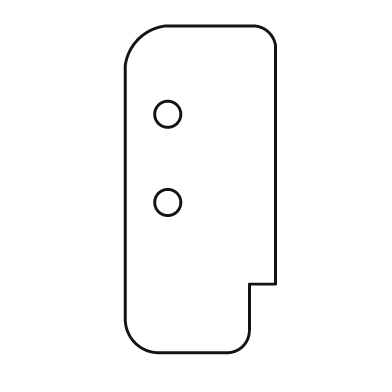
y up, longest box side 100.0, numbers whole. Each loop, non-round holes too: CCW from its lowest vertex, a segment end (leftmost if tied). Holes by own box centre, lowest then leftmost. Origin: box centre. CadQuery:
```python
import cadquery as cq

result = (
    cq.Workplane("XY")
    .moveTo(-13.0, -50.0)
    .lineTo(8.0, -50.0)
    .threePointArc((13.0, -48.0), (15.0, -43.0))
    .lineTo(15.0, -29.0)
    .lineTo(23.0, -29.0)
    .lineTo(23.0, 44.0)
    .threePointArc((21.0, 48.0), (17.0, 50.0))
    .lineTo(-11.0, 50.0)
    .threePointArc((-19.0, 46.0), (-23.0, 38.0))
    .lineTo(-23.0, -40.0)
    .threePointArc((-20.0, -47.0), (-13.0, -50.0))
    .close()
    .moveTo(-10.0, -4.0)
    .circle(4.0)
    .moveTo(-10.0, 23.0)
    .circle(4.0)
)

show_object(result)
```